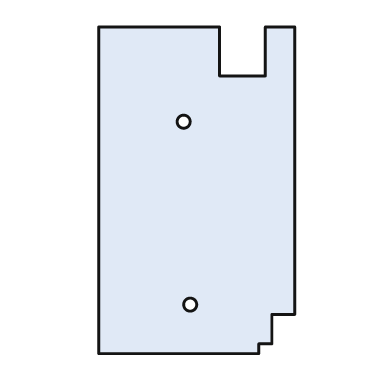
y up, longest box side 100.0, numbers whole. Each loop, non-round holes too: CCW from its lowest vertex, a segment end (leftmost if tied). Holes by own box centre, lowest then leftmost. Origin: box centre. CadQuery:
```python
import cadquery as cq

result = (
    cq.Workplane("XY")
    .moveTo(-30.0, -50.0)
    .lineTo(19.0, -50.0)
    .lineTo(19.0, -47.0)
    .lineTo(23.0, -47.0)
    .lineTo(23.0, -38.0)
    .lineTo(30.0, -38.0)
    .lineTo(30.0, 50.0)
    .lineTo(21.0, 50.0)
    .lineTo(21.0, 35.0)
    .lineTo(7.0, 35.0)
    .lineTo(7.0, 50.0)
    .lineTo(-30.0, 50.0)
    .close()
    .moveTo(-2.0, -35.0)
    .circle(2.0)
    .moveTo(-4.0, 21.0)
    .circle(2.0)
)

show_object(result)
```